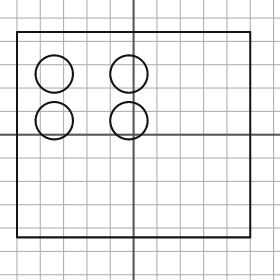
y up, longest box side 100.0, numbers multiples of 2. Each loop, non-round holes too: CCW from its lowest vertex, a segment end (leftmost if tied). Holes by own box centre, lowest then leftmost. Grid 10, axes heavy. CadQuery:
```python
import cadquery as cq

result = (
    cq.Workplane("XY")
    .moveTo(-50.0, -44.0)
    .lineTo(50.0, -44.0)
    .lineTo(50.0, 44.0)
    .lineTo(-50.0, 44.0)
    .close()
    .moveTo(-34.0, 6.0)
    .circle(8.0)
    .moveTo(-2.0, 6.0)
    .circle(8.0)
    .moveTo(-34.0, 26.0)
    .circle(8.0)
    .moveTo(-2.0, 26.0)
    .circle(8.0)
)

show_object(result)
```